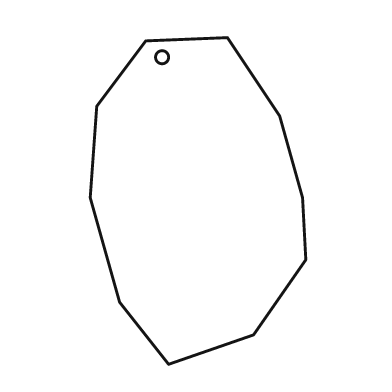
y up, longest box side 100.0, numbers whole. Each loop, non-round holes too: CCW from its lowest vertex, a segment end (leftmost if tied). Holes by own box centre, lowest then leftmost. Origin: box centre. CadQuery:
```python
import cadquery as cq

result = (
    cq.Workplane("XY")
    .moveTo(-9.0, -50.0)
    .lineTo(17.0, -41.0)
    .lineTo(33.0, -18.0)
    .lineTo(32.0, 1.0)
    .lineTo(25.0, 26.0)
    .lineTo(9.0, 50.0)
    .lineTo(-16.0, 49.0)
    .lineTo(-31.0, 29.0)
    .lineTo(-33.0, 1.0)
    .lineTo(-24.0, -31.0)
    .close()
    .moveTo(-11.0, 44.0)
    .circle(2.0)
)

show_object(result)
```